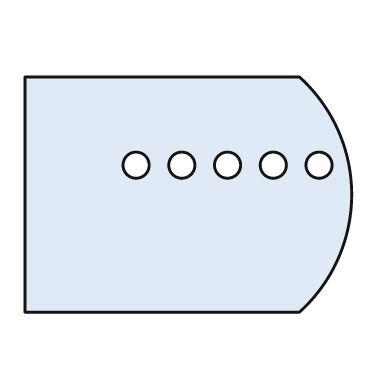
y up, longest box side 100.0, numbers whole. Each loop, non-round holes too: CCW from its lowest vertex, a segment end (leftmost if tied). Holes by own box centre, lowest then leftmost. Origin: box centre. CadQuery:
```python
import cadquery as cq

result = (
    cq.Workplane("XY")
    .moveTo(-50.0, -36.0)
    .lineTo(34.0, -36.0)
    .threePointArc((50.0, 0.0), (34.0, 36.0))
    .lineTo(-50.0, 36.0)
    .close()
    .moveTo(-16.0, 9.0)
    .circle(4.0)
    .moveTo(-2.0, 9.0)
    .circle(4.0)
    .moveTo(12.0, 9.0)
    .circle(4.0)
    .moveTo(26.0, 9.0)
    .circle(4.0)
    .moveTo(40.0, 9.0)
    .circle(4.0)
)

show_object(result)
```